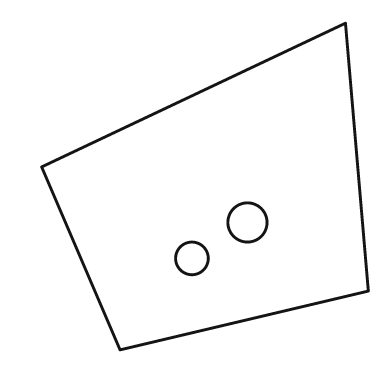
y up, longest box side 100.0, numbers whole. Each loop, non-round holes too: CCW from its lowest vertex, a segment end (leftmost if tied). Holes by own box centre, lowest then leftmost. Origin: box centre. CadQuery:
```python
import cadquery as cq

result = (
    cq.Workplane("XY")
    .moveTo(-26.0, -50.0)
    .lineTo(50.0, -32.0)
    .lineTo(43.0, 50.0)
    .lineTo(-50.0, 6.0)
    .close()
    .moveTo(-4.0, -22.0)
    .circle(5.0)
    .moveTo(13.0, -11.0)
    .circle(6.0)
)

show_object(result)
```